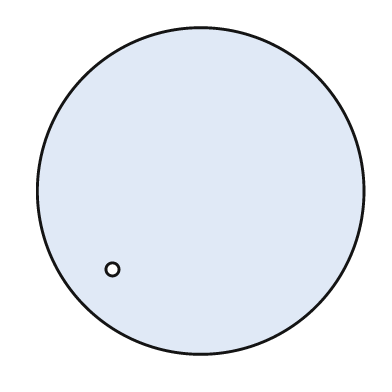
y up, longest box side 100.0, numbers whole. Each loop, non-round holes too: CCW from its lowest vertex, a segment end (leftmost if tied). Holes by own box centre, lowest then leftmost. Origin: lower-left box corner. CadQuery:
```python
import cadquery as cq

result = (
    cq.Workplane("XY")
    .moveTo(50.0, 50.0)
    .circle(50.0)
    .moveTo(23.0, 26.0)
    .circle(2.0)
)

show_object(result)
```